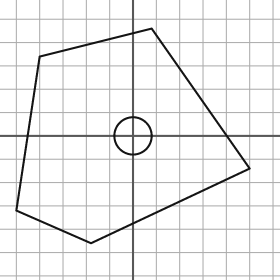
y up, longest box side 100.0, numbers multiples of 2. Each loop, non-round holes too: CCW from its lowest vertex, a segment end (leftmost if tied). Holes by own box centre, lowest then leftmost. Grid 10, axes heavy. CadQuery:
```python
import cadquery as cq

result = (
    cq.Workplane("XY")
    .moveTo(-18.0, -46.0)
    .lineTo(50.0, -14.0)
    .lineTo(8.0, 46.0)
    .lineTo(-40.0, 34.0)
    .lineTo(-50.0, -32.0)
    .close()
    .moveTo(0.0, 0.0)
    .circle(8.0)
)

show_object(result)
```